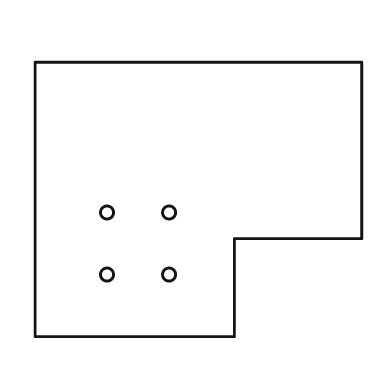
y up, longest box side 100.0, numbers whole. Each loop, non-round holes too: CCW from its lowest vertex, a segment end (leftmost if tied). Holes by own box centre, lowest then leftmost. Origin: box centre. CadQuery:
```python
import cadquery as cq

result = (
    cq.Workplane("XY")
    .moveTo(-50.0, -42.0)
    .lineTo(11.0, -42.0)
    .lineTo(11.0, -12.0)
    .lineTo(50.0, -12.0)
    .lineTo(50.0, 42.0)
    .lineTo(-50.0, 42.0)
    .close()
    .moveTo(-28.0, -23.0)
    .circle(2.0)
    .moveTo(-9.0, -23.0)
    .circle(2.0)
    .moveTo(-28.0, -4.0)
    .circle(2.0)
    .moveTo(-9.0, -4.0)
    .circle(2.0)
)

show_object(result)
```